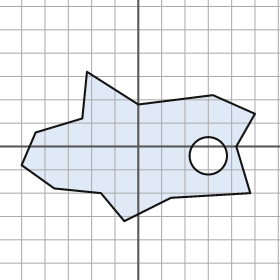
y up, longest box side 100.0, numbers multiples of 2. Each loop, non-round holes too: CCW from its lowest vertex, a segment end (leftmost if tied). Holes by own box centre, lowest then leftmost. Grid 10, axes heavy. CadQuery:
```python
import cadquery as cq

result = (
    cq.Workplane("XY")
    .moveTo(-6.0, -32.0)
    .lineTo(14.0, -22.0)
    .lineTo(48.0, -20.0)
    .lineTo(42.0, 0.0)
    .lineTo(50.0, 14.0)
    .lineTo(32.0, 22.0)
    .lineTo(0.0, 18.0)
    .lineTo(-22.0, 32.0)
    .lineTo(-24.0, 12.0)
    .lineTo(-44.0, 6.0)
    .lineTo(-50.0, -8.0)
    .lineTo(-36.0, -18.0)
    .lineTo(-16.0, -20.0)
    .close()
    .moveTo(30.0, -4.0)
    .circle(8.0)
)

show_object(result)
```